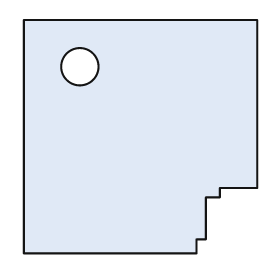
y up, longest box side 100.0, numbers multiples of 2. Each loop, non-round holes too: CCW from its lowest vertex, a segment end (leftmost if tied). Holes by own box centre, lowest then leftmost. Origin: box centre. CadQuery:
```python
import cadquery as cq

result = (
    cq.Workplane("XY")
    .moveTo(-50.0, -50.0)
    .lineTo(24.0, -50.0)
    .lineTo(24.0, -44.0)
    .lineTo(28.0, -44.0)
    .lineTo(28.0, -26.0)
    .lineTo(34.0, -26.0)
    .lineTo(34.0, -22.0)
    .lineTo(50.0, -22.0)
    .lineTo(50.0, 50.0)
    .lineTo(-50.0, 50.0)
    .close()
    .moveTo(-26.0, 30.0)
    .circle(8.0)
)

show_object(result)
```